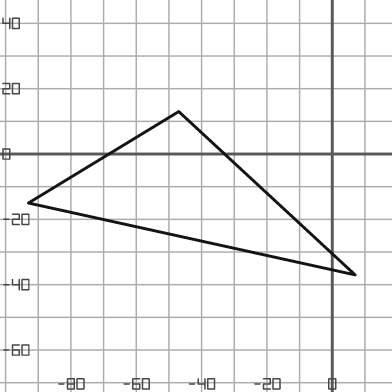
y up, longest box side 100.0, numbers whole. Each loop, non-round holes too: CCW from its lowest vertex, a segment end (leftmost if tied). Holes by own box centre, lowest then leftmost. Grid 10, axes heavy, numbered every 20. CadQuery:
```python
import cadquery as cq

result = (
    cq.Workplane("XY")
    .moveTo(7.0, -37.0)
    .lineTo(-47.0, 13.0)
    .lineTo(-93.0, -15.0)
    .close()
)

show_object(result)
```